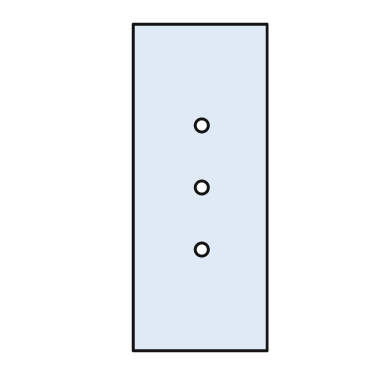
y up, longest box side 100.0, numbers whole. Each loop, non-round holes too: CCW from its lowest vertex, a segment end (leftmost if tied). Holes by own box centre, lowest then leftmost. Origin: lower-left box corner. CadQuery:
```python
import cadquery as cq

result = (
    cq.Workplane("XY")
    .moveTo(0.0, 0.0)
    .lineTo(41.0, 0.0)
    .lineTo(41.0, 100.0)
    .lineTo(0.0, 100.0)
    .close()
    .moveTo(21.0, 31.0)
    .circle(2.0)
    .moveTo(21.0, 50.0)
    .circle(2.0)
    .moveTo(21.0, 69.0)
    .circle(2.0)
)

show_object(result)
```